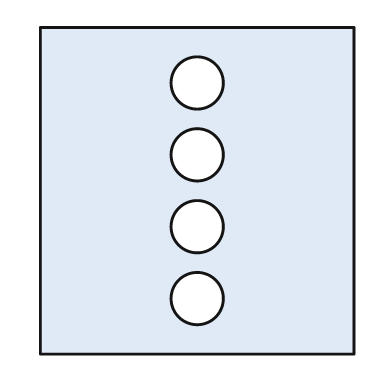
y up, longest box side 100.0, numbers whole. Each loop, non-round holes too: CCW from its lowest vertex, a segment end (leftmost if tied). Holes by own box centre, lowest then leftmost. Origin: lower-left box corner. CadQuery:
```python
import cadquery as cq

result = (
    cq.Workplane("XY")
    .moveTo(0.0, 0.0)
    .lineTo(96.0, 0.0)
    .lineTo(96.0, 100.0)
    .lineTo(0.0, 100.0)
    .close()
    .moveTo(48.0, 17.0)
    .circle(8.0)
    .moveTo(48.0, 39.0)
    .circle(8.0)
    .moveTo(48.0, 61.0)
    .circle(8.0)
    .moveTo(48.0, 83.0)
    .circle(8.0)
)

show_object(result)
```